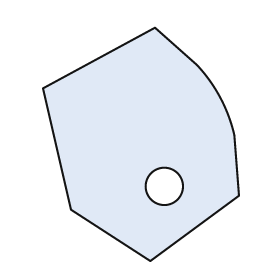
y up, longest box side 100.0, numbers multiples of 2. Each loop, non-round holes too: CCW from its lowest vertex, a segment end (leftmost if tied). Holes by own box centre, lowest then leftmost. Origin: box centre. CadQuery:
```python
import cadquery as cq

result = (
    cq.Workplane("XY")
    .moveTo(4.0, -50.0)
    .lineTo(42.0, -22.0)
    .lineTo(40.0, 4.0)
    .threePointArc((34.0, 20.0), (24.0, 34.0))
    .lineTo(6.0, 50.0)
    .lineTo(-42.0, 24.0)
    .lineTo(-30.0, -28.0)
    .close()
    .moveTo(10.0, -18.0)
    .circle(8.0)
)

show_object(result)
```